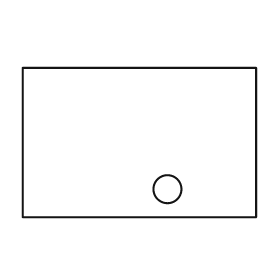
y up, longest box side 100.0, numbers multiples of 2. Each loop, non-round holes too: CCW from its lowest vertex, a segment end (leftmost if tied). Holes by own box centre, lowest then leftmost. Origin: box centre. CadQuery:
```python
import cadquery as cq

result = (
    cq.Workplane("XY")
    .moveTo(-50.0, -32.0)
    .lineTo(50.0, -32.0)
    .lineTo(50.0, 32.0)
    .lineTo(-50.0, 32.0)
    .close()
    .moveTo(12.0, -20.0)
    .circle(6.0)
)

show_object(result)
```